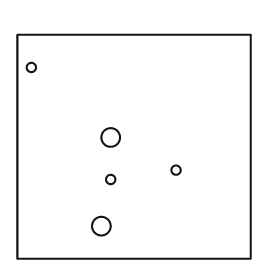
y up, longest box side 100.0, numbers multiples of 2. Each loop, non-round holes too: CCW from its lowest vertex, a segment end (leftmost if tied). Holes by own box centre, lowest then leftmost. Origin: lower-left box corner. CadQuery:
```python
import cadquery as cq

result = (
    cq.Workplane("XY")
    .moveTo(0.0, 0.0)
    .lineTo(100.0, 0.0)
    .lineTo(100.0, 96.0)
    .lineTo(0.0, 96.0)
    .close()
    .moveTo(36.0, 14.0)
    .circle(4.0)
    .moveTo(40.0, 34.0)
    .circle(2.0)
    .moveTo(68.0, 38.0)
    .circle(2.0)
    .moveTo(40.0, 52.0)
    .circle(4.0)
    .moveTo(6.0, 82.0)
    .circle(2.0)
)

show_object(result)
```